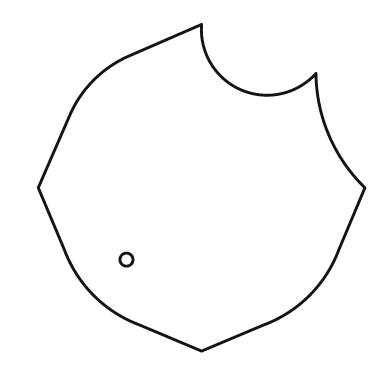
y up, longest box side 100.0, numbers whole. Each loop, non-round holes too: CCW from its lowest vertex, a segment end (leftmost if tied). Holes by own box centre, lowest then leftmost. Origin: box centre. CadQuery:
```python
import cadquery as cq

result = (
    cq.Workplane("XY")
    .moveTo(0.0, -50.0)
    .lineTo(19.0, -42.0)
    .threePointArc((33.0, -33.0), (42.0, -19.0))
    .lineTo(50.0, 0.0)
    .threePointArc((39.0, 16.0), (35.0, 35.0))
    .threePointArc((12.0, 30.0), (0.0, 50.0))
    .lineTo(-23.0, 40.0)
    .threePointArc((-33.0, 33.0), (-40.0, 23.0))
    .lineTo(-50.0, 0.0)
    .lineTo(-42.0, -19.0)
    .threePointArc((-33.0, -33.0), (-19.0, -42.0))
    .close()
    .moveTo(-23.0, -22.0)
    .circle(2.0)
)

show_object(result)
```